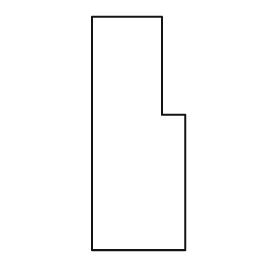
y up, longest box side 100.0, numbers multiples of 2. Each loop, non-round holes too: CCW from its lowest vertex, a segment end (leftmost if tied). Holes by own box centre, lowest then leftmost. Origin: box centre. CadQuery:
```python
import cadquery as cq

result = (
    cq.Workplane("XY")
    .moveTo(-20.0, -50.0)
    .lineTo(20.0, -50.0)
    .lineTo(20.0, 8.0)
    .lineTo(10.0, 8.0)
    .lineTo(10.0, 50.0)
    .lineTo(-20.0, 50.0)
    .close()
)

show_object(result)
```